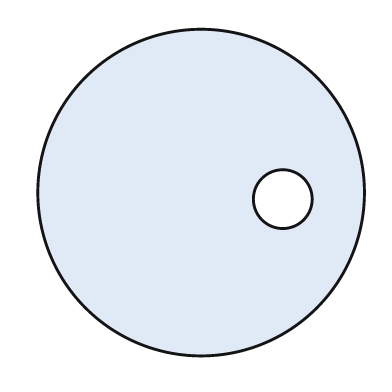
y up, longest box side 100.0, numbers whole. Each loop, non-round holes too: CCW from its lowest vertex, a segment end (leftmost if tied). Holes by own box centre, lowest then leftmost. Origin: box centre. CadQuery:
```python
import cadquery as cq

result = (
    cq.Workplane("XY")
    .moveTo(0.0, 0.0)
    .circle(50.0)
    .moveTo(25.0, -2.0)
    .circle(9.0)
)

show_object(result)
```